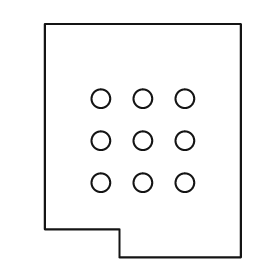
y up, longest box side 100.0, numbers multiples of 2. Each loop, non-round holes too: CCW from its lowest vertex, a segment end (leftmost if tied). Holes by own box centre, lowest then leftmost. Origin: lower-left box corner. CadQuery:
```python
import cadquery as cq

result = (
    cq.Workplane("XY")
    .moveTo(32.0, 0.0)
    .lineTo(84.0, 0.0)
    .lineTo(84.0, 100.0)
    .lineTo(0.0, 100.0)
    .lineTo(0.0, 12.0)
    .lineTo(32.0, 12.0)
    .close()
    .moveTo(24.0, 32.0)
    .circle(4.0)
    .moveTo(42.0, 32.0)
    .circle(4.0)
    .moveTo(60.0, 32.0)
    .circle(4.0)
    .moveTo(24.0, 50.0)
    .circle(4.0)
    .moveTo(42.0, 50.0)
    .circle(4.0)
    .moveTo(60.0, 50.0)
    .circle(4.0)
    .moveTo(24.0, 68.0)
    .circle(4.0)
    .moveTo(42.0, 68.0)
    .circle(4.0)
    .moveTo(60.0, 68.0)
    .circle(4.0)
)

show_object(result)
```